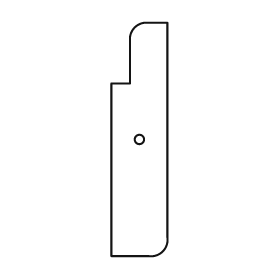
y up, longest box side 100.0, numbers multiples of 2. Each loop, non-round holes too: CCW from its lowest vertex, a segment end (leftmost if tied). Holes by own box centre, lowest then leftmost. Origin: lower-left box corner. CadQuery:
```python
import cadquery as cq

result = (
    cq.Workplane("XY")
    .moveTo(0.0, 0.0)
    .lineTo(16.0, 0.0)
    .threePointArc((22.0, 2.0), (24.0, 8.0))
    .lineTo(24.0, 100.0)
    .lineTo(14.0, 100.0)
    .threePointArc((10.0, 98.0), (8.0, 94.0))
    .lineTo(8.0, 74.0)
    .lineTo(0.0, 74.0)
    .close()
    .moveTo(12.0, 50.0)
    .circle(2.0)
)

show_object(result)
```